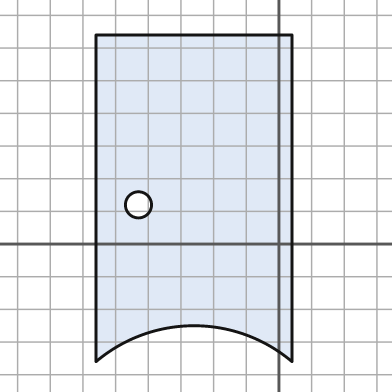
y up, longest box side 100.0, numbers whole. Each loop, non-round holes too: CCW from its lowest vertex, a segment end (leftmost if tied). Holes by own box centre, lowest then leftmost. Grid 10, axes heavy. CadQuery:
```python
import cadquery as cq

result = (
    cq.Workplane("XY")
    .moveTo(-56.0, -36.0)
    .threePointArc((-26.0, -25.0), (4.0, -36.0))
    .lineTo(4.0, 64.0)
    .lineTo(-56.0, 64.0)
    .close()
    .moveTo(-43.0, 12.0)
    .circle(4.0)
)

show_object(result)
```